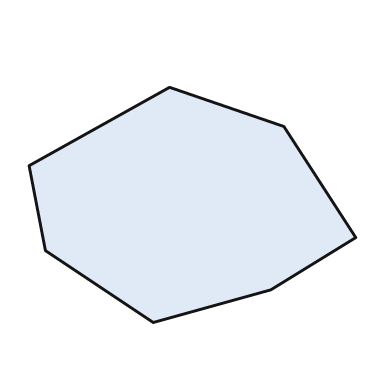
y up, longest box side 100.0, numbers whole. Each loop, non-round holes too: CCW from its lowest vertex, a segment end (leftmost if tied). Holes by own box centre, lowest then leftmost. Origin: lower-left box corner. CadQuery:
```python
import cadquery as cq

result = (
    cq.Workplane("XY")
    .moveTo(38.0, 0.0)
    .lineTo(74.0, 10.0)
    .lineTo(100.0, 26.0)
    .lineTo(78.0, 60.0)
    .lineTo(43.0, 72.0)
    .lineTo(0.0, 48.0)
    .lineTo(5.0, 22.0)
    .close()
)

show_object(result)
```